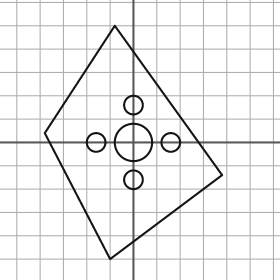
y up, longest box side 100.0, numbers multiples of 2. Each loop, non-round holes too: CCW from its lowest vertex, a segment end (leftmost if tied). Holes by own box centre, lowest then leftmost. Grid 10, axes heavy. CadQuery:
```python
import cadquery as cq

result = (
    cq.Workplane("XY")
    .moveTo(-10.0, -50.0)
    .lineTo(38.0, -14.0)
    .lineTo(-8.0, 50.0)
    .lineTo(-38.0, 4.0)
    .close()
    .moveTo(0.0, -16.0)
    .circle(4.0)
    .moveTo(-16.0, 0.0)
    .circle(4.0)
    .moveTo(0.0, 0.0)
    .circle(8.0)
    .moveTo(16.0, 0.0)
    .circle(4.0)
    .moveTo(0.0, 16.0)
    .circle(4.0)
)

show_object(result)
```